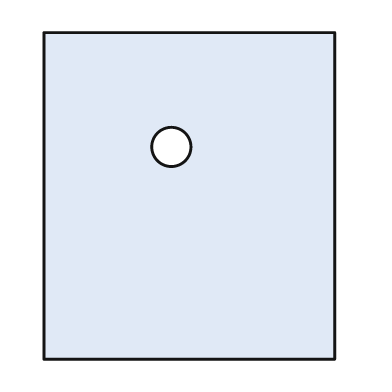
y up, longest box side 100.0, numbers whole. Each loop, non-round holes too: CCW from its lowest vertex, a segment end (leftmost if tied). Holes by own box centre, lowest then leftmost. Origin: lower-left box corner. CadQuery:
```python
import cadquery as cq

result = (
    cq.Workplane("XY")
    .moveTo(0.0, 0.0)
    .lineTo(89.0, 0.0)
    .lineTo(89.0, 100.0)
    .lineTo(0.0, 100.0)
    .close()
    .moveTo(39.0, 65.0)
    .circle(6.0)
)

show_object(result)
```